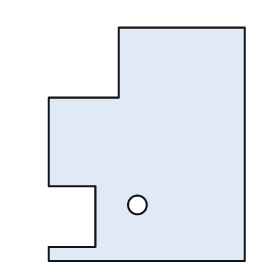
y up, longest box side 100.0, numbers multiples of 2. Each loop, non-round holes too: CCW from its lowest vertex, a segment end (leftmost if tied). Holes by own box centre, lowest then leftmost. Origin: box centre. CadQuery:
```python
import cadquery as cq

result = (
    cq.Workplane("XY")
    .moveTo(-42.0, -50.0)
    .lineTo(42.0, -50.0)
    .lineTo(42.0, 50.0)
    .lineTo(-12.0, 50.0)
    .lineTo(-12.0, 20.0)
    .lineTo(-42.0, 20.0)
    .lineTo(-42.0, -18.0)
    .lineTo(-22.0, -18.0)
    .lineTo(-22.0, -44.0)
    .lineTo(-42.0, -44.0)
    .close()
    .moveTo(-4.0, -26.0)
    .circle(4.0)
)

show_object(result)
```